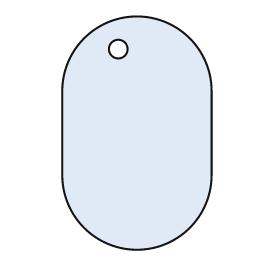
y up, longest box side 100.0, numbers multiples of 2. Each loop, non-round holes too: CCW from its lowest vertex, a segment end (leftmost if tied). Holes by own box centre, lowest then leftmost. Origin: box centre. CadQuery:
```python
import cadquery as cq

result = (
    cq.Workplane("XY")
    .moveTo(-32.0, -18.0)
    .threePointArc((0.0, -50.0), (32.0, -18.0))
    .lineTo(32.0, 18.0)
    .threePointArc((0.0, 50.0), (-32.0, 18.0))
    .close()
    .moveTo(-8.0, 36.0)
    .circle(4.0)
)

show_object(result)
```